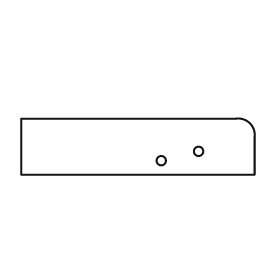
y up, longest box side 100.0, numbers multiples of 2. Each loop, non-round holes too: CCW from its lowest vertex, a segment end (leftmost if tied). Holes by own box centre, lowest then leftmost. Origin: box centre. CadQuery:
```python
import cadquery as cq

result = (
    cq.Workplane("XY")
    .moveTo(-50.0, -12.0)
    .lineTo(50.0, -12.0)
    .lineTo(50.0, 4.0)
    .threePointArc((48.0, 10.0), (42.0, 12.0))
    .lineTo(-50.0, 12.0)
    .close()
    .moveTo(10.0, -6.0)
    .circle(2.0)
    .moveTo(26.0, -2.0)
    .circle(2.0)
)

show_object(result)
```